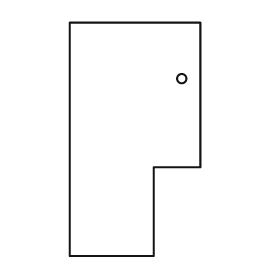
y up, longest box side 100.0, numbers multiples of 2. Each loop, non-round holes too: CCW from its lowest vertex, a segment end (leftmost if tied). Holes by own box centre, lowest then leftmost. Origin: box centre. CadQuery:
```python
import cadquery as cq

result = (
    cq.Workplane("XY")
    .moveTo(-28.0, -50.0)
    .lineTo(8.0, -50.0)
    .lineTo(8.0, -12.0)
    .lineTo(28.0, -12.0)
    .lineTo(28.0, 50.0)
    .lineTo(-28.0, 50.0)
    .close()
    .moveTo(20.0, 26.0)
    .circle(2.0)
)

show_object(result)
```